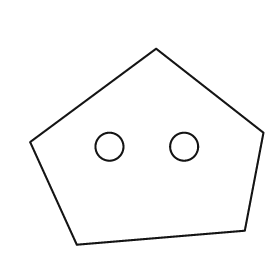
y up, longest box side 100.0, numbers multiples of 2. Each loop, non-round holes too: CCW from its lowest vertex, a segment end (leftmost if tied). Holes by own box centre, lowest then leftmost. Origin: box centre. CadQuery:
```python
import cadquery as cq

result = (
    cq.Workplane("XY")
    .moveTo(-30.0, -42.0)
    .lineTo(42.0, -36.0)
    .lineTo(50.0, 6.0)
    .lineTo(4.0, 42.0)
    .lineTo(-50.0, 2.0)
    .close()
    .moveTo(-16.0, 0.0)
    .circle(6.0)
    .moveTo(16.0, 0.0)
    .circle(6.0)
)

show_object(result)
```